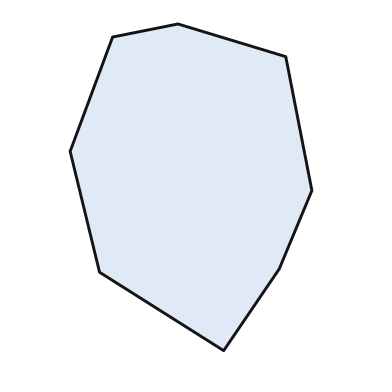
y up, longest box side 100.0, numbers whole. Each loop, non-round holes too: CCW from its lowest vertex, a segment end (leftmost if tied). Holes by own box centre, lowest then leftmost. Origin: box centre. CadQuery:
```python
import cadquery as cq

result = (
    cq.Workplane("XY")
    .moveTo(10.0, -50.0)
    .lineTo(27.0, -25.0)
    .lineTo(37.0, -1.0)
    .lineTo(29.0, 40.0)
    .lineTo(-4.0, 50.0)
    .lineTo(-24.0, 46.0)
    .lineTo(-37.0, 11.0)
    .lineTo(-28.0, -26.0)
    .close()
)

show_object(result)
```